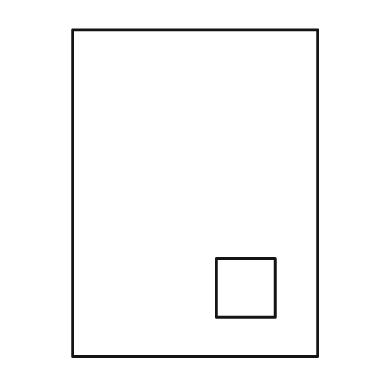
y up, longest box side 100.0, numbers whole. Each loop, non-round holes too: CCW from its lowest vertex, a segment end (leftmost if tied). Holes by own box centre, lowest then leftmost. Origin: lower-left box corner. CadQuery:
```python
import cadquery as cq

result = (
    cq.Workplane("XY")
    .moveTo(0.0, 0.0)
    .lineTo(75.0, 0.0)
    .lineTo(75.0, 100.0)
    .lineTo(0.0, 100.0)
    .close()
    .moveTo(44.0, 12.0)
    .lineTo(62.0, 12.0)
    .lineTo(62.0, 30.0)
    .lineTo(44.0, 30.0)
    .close()
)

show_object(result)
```